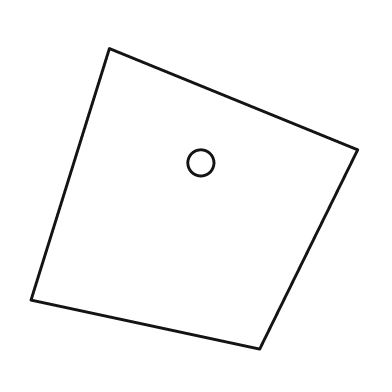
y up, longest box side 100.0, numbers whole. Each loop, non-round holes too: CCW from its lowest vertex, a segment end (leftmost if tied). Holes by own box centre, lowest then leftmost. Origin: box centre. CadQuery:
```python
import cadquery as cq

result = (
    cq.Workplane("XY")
    .moveTo(20.0, -46.0)
    .lineTo(50.0, 15.0)
    .lineTo(-26.0, 46.0)
    .lineTo(-50.0, -31.0)
    .close()
    .moveTo(2.0, 11.0)
    .circle(4.0)
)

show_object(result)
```